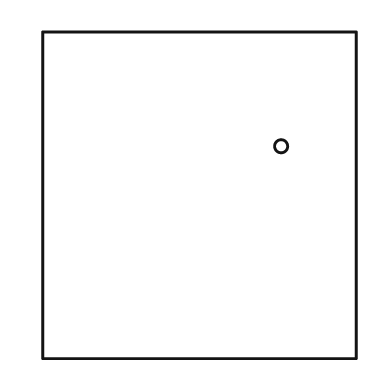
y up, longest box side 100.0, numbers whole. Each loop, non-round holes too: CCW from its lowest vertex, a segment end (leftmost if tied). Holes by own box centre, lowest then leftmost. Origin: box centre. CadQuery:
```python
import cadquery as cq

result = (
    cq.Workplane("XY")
    .moveTo(-48.0, -50.0)
    .lineTo(48.0, -50.0)
    .lineTo(48.0, 50.0)
    .lineTo(-48.0, 50.0)
    .close()
    .moveTo(25.0, 15.0)
    .circle(2.0)
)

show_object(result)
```